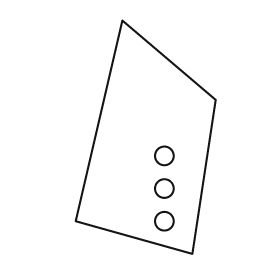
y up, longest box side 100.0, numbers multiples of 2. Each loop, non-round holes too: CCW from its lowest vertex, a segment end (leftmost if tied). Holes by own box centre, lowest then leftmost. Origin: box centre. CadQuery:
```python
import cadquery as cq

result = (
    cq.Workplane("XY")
    .moveTo(20.0, -50.0)
    .lineTo(30.0, 16.0)
    .lineTo(-10.0, 50.0)
    .lineTo(-30.0, -36.0)
    .close()
    .moveTo(8.0, -36.0)
    .circle(4.0)
    .moveTo(8.0, -22.0)
    .circle(4.0)
    .moveTo(8.0, -8.0)
    .circle(4.0)
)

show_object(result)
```